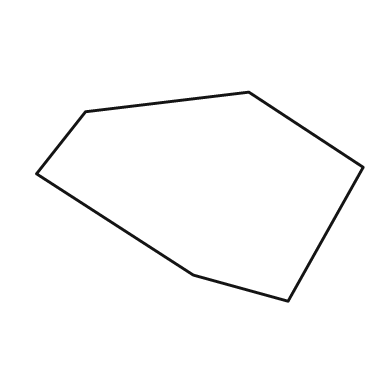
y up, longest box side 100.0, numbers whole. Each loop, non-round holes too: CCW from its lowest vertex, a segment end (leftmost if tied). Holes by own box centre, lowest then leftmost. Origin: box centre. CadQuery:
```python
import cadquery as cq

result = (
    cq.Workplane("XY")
    .moveTo(27.0, -32.0)
    .lineTo(50.0, 9.0)
    .lineTo(15.0, 32.0)
    .lineTo(-35.0, 26.0)
    .lineTo(-50.0, 7.0)
    .lineTo(-2.0, -24.0)
    .close()
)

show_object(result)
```